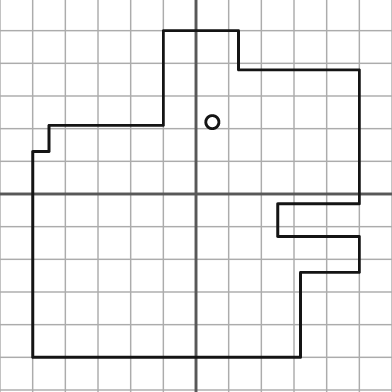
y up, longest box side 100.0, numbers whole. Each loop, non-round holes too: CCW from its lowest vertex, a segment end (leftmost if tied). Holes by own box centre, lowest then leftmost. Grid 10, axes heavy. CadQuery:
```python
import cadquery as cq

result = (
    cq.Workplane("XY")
    .moveTo(-50.0, -50.0)
    .lineTo(32.0, -50.0)
    .lineTo(32.0, -24.0)
    .lineTo(50.0, -24.0)
    .lineTo(50.0, -13.0)
    .lineTo(25.0, -13.0)
    .lineTo(25.0, -3.0)
    .lineTo(50.0, -3.0)
    .lineTo(50.0, 38.0)
    .lineTo(13.0, 38.0)
    .lineTo(13.0, 50.0)
    .lineTo(-10.0, 50.0)
    .lineTo(-10.0, 21.0)
    .lineTo(-45.0, 21.0)
    .lineTo(-45.0, 13.0)
    .lineTo(-50.0, 13.0)
    .close()
    .moveTo(5.0, 22.0)
    .circle(2.0)
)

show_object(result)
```